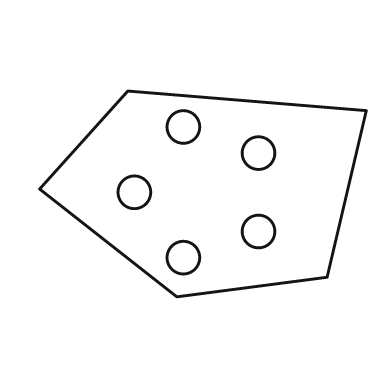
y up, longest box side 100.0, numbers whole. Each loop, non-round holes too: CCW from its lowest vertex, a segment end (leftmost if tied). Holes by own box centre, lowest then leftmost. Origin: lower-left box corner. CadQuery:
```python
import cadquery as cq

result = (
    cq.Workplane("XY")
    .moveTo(42.0, 0.0)
    .lineTo(88.0, 6.0)
    .lineTo(100.0, 57.0)
    .lineTo(27.0, 63.0)
    .lineTo(0.0, 33.0)
    .close()
    .moveTo(44.0, 12.0)
    .circle(5.0)
    .moveTo(67.0, 20.0)
    .circle(5.0)
    .moveTo(29.0, 32.0)
    .circle(5.0)
    .moveTo(67.0, 44.0)
    .circle(5.0)
    .moveTo(44.0, 52.0)
    .circle(5.0)
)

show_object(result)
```